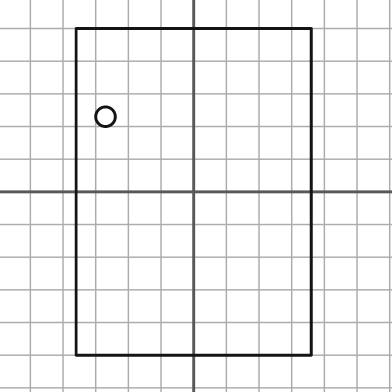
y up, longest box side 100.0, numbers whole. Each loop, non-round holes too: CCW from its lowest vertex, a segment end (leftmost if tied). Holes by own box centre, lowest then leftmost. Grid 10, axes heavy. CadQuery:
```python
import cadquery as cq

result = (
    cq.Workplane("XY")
    .moveTo(-36.0, -50.0)
    .lineTo(36.0, -50.0)
    .lineTo(36.0, 50.0)
    .lineTo(-36.0, 50.0)
    .close()
    .moveTo(-27.0, 23.0)
    .circle(3.0)
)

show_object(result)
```